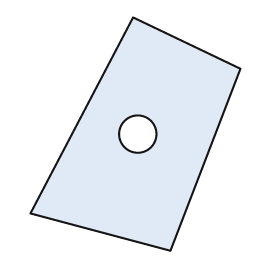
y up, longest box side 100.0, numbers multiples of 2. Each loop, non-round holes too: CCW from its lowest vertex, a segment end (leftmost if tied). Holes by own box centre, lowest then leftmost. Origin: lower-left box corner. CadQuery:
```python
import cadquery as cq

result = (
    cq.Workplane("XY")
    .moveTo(60.0, 0.0)
    .lineTo(90.0, 78.0)
    .lineTo(44.0, 100.0)
    .lineTo(0.0, 16.0)
    .close()
    .moveTo(46.0, 50.0)
    .circle(8.0)
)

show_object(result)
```